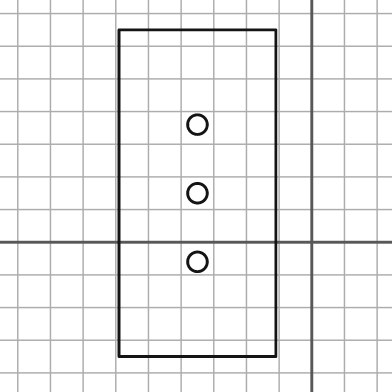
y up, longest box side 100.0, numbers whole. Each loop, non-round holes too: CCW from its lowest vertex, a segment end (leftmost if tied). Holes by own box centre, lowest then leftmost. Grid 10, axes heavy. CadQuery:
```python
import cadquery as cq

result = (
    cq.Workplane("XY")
    .moveTo(-59.0, -35.0)
    .lineTo(-11.0, -35.0)
    .lineTo(-11.0, 65.0)
    .lineTo(-59.0, 65.0)
    .close()
    .moveTo(-35.0, -6.0)
    .circle(3.0)
    .moveTo(-35.0, 15.0)
    .circle(3.0)
    .moveTo(-35.0, 36.0)
    .circle(3.0)
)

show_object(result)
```